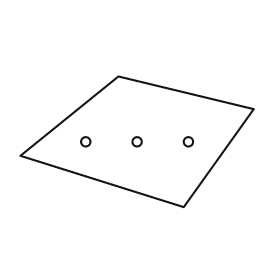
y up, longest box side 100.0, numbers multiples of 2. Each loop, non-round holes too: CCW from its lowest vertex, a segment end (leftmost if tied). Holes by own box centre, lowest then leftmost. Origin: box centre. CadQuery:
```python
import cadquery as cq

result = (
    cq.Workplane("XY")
    .moveTo(20.0, -28.0)
    .lineTo(50.0, 14.0)
    .lineTo(-8.0, 28.0)
    .lineTo(-50.0, -6.0)
    .close()
    .moveTo(-22.0, 0.0)
    .circle(2.0)
    .moveTo(0.0, 0.0)
    .circle(2.0)
    .moveTo(22.0, 0.0)
    .circle(2.0)
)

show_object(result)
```